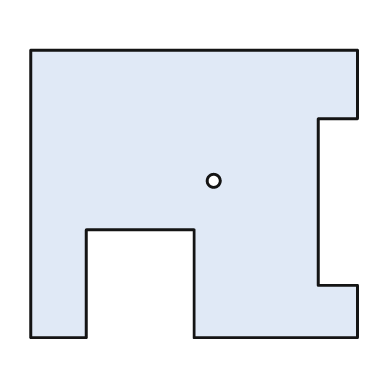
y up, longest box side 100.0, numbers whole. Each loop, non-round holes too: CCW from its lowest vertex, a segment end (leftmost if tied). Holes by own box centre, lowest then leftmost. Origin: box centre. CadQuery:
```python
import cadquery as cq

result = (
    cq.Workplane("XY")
    .moveTo(-50.0, -44.0)
    .lineTo(-33.0, -44.0)
    .lineTo(-33.0, -11.0)
    .lineTo(0.0, -11.0)
    .lineTo(0.0, -44.0)
    .lineTo(50.0, -44.0)
    .lineTo(50.0, -28.0)
    .lineTo(38.0, -28.0)
    .lineTo(38.0, 23.0)
    .lineTo(50.0, 23.0)
    .lineTo(50.0, 44.0)
    .lineTo(-50.0, 44.0)
    .close()
    .moveTo(6.0, 4.0)
    .circle(2.0)
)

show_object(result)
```